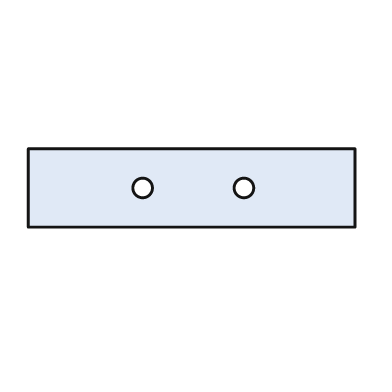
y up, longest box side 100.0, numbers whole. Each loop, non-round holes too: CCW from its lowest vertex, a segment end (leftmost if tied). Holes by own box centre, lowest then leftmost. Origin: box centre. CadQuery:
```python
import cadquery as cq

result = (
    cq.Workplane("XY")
    .moveTo(-50.0, -12.0)
    .lineTo(50.0, -12.0)
    .lineTo(50.0, 12.0)
    .lineTo(-50.0, 12.0)
    .close()
    .moveTo(-15.0, 0.0)
    .circle(3.0)
    .moveTo(16.0, 0.0)
    .circle(3.0)
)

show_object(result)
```